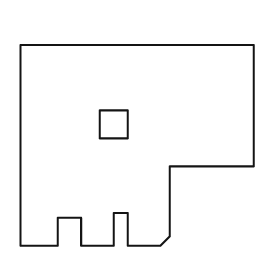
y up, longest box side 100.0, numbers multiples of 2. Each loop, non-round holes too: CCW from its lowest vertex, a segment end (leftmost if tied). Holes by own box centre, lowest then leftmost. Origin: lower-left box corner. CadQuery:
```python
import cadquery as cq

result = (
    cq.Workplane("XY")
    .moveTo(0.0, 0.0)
    .lineTo(16.0, 0.0)
    .lineTo(16.0, 12.0)
    .lineTo(26.0, 12.0)
    .lineTo(26.0, 0.0)
    .lineTo(40.0, 0.0)
    .lineTo(40.0, 14.0)
    .lineTo(46.0, 14.0)
    .lineTo(46.0, 0.0)
    .lineTo(60.0, 0.0)
    .lineTo(64.0, 4.0)
    .lineTo(64.0, 34.0)
    .lineTo(100.0, 34.0)
    .lineTo(100.0, 86.0)
    .lineTo(0.0, 86.0)
    .close()
    .moveTo(34.0, 46.0)
    .lineTo(46.0, 46.0)
    .lineTo(46.0, 58.0)
    .lineTo(34.0, 58.0)
    .close()
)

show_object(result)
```